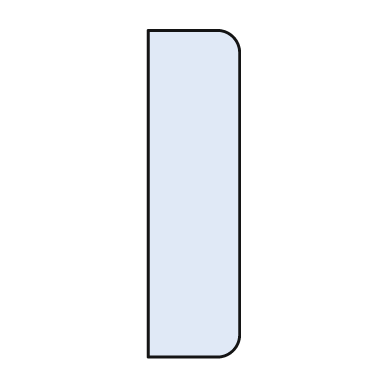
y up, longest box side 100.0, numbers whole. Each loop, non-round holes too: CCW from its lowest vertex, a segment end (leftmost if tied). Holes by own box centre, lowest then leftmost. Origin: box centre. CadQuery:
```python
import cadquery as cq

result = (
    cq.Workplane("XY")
    .moveTo(-14.0, -50.0)
    .lineTo(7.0, -50.0)
    .threePointArc((12.0, -48.0), (14.0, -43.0))
    .lineTo(14.0, 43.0)
    .threePointArc((12.0, 48.0), (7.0, 50.0))
    .lineTo(-14.0, 50.0)
    .close()
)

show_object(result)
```